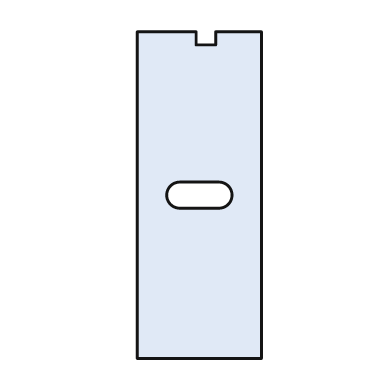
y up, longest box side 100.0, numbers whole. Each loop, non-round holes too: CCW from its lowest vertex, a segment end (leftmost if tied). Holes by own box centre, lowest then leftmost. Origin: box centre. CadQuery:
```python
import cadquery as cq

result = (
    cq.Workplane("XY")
    .moveTo(-19.0, -50.0)
    .lineTo(19.0, -50.0)
    .lineTo(19.0, 50.0)
    .lineTo(5.0, 50.0)
    .lineTo(5.0, 46.0)
    .lineTo(-1.0, 46.0)
    .lineTo(-1.0, 50.0)
    .lineTo(-19.0, 50.0)
    .close()
    .moveTo(-6.0, -4.0)
    .lineTo(6.0, -4.0)
    .threePointArc((10.0, 0.0), (6.0, 4.0))
    .lineTo(-6.0, 4.0)
    .threePointArc((-10.0, 0.0), (-6.0, -4.0))
    .close()
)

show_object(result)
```